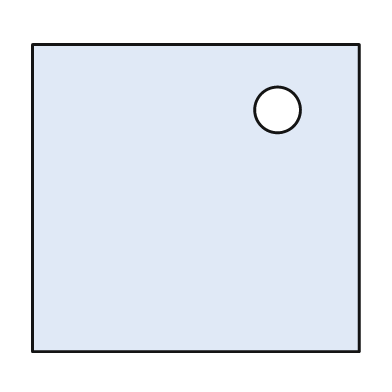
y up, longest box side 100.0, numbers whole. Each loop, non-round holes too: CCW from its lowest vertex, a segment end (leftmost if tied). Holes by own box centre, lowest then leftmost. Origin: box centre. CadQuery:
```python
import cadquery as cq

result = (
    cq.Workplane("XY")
    .moveTo(-50.0, -47.0)
    .lineTo(50.0, -47.0)
    .lineTo(50.0, 47.0)
    .lineTo(-50.0, 47.0)
    .close()
    .moveTo(25.0, 27.0)
    .circle(7.0)
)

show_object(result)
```